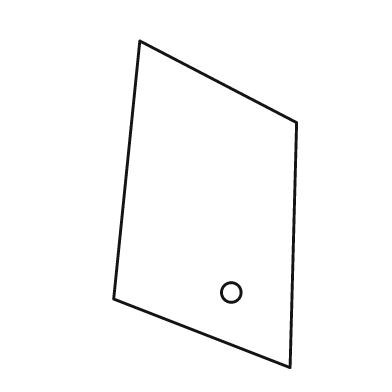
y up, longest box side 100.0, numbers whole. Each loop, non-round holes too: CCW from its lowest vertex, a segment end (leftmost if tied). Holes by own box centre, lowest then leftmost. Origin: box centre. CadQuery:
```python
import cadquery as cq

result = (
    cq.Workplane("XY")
    .moveTo(26.0, -50.0)
    .lineTo(28.0, 25.0)
    .lineTo(-20.0, 50.0)
    .lineTo(-28.0, -29.0)
    .close()
    .moveTo(8.0, -27.0)
    .circle(3.0)
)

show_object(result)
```